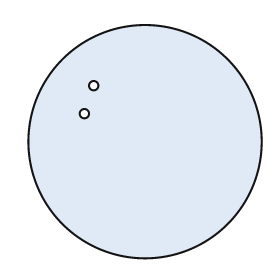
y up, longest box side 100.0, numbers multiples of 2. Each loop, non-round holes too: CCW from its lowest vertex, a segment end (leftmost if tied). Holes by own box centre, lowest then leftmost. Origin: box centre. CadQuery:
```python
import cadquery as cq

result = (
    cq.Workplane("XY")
    .moveTo(0.0, 0.0)
    .circle(50.0)
    .moveTo(-26.0, 12.0)
    .circle(2.0)
    .moveTo(-22.0, 24.0)
    .circle(2.0)
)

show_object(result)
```